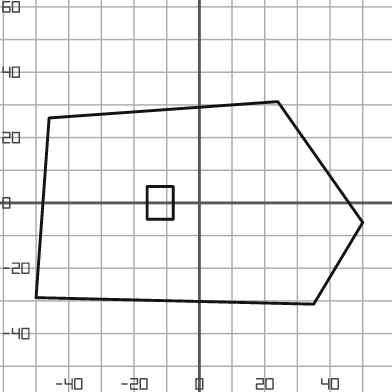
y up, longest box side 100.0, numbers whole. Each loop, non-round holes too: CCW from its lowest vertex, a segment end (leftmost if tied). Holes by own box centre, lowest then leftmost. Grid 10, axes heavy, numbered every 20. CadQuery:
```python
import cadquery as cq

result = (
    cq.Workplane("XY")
    .moveTo(35.0, -31.0)
    .lineTo(50.0, -6.0)
    .lineTo(24.0, 31.0)
    .lineTo(-46.0, 26.0)
    .lineTo(-50.0, -29.0)
    .close()
    .moveTo(-16.0, -5.0)
    .lineTo(-8.0, -5.0)
    .lineTo(-8.0, 5.0)
    .lineTo(-16.0, 5.0)
    .close()
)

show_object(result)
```